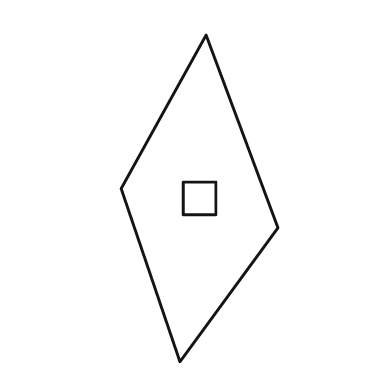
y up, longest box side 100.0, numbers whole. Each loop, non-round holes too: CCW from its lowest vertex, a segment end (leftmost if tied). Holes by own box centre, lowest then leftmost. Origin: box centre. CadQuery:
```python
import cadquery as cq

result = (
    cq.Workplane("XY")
    .moveTo(-6.0, -50.0)
    .lineTo(24.0, -9.0)
    .lineTo(2.0, 50.0)
    .lineTo(-24.0, 3.0)
    .close()
    .moveTo(-5.0, -5.0)
    .lineTo(5.0, -5.0)
    .lineTo(5.0, 5.0)
    .lineTo(-5.0, 5.0)
    .close()
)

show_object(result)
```